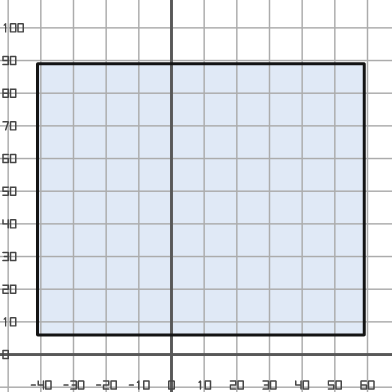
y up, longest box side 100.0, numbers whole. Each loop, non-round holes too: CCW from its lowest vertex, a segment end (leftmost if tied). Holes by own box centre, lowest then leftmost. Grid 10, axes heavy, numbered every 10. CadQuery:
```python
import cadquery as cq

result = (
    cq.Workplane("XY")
    .moveTo(-41.0, 6.0)
    .lineTo(59.0, 6.0)
    .lineTo(59.0, 89.0)
    .lineTo(-41.0, 89.0)
    .close()
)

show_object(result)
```